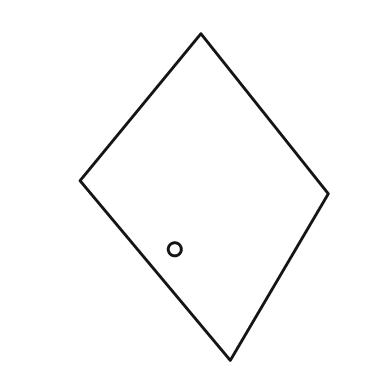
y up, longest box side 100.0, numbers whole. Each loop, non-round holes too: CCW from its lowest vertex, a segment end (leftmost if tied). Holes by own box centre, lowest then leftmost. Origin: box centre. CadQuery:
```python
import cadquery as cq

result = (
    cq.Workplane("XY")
    .moveTo(8.0, -50.0)
    .lineTo(38.0, 1.0)
    .lineTo(-1.0, 50.0)
    .lineTo(-38.0, 5.0)
    .close()
    .moveTo(-9.0, -16.0)
    .circle(2.0)
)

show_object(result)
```